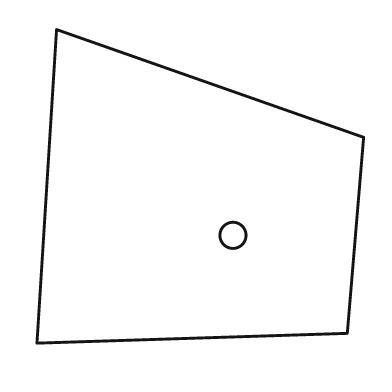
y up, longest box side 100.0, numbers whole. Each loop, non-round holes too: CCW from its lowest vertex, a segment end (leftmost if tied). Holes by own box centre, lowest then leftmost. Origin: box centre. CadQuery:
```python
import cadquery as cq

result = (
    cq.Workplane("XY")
    .moveTo(-50.0, -48.0)
    .lineTo(45.0, -45.0)
    .lineTo(50.0, 15.0)
    .lineTo(-44.0, 48.0)
    .close()
    .moveTo(10.0, -15.0)
    .circle(4.0)
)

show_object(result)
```